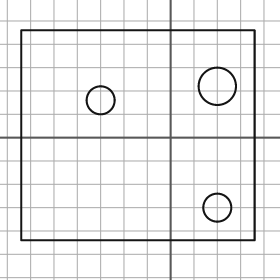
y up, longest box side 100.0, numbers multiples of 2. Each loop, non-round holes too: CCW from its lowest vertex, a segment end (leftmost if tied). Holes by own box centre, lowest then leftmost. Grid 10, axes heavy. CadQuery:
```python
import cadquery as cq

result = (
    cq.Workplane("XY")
    .moveTo(-64.0, -44.0)
    .lineTo(36.0, -44.0)
    .lineTo(36.0, 46.0)
    .lineTo(-64.0, 46.0)
    .close()
    .moveTo(20.0, -30.0)
    .circle(6.0)
    .moveTo(-30.0, 16.0)
    .circle(6.0)
    .moveTo(20.0, 22.0)
    .circle(8.0)
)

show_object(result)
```